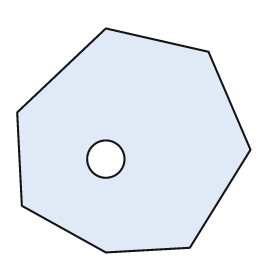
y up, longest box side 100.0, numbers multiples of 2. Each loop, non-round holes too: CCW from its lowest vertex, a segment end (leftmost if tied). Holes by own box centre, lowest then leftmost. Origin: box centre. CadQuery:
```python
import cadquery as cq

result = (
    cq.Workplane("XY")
    .moveTo(-12.0, -48.0)
    .lineTo(24.0, -46.0)
    .lineTo(50.0, -4.0)
    .lineTo(32.0, 38.0)
    .lineTo(-12.0, 48.0)
    .lineTo(-50.0, 12.0)
    .lineTo(-48.0, -28.0)
    .close()
    .moveTo(-12.0, -8.0)
    .circle(8.0)
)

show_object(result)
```